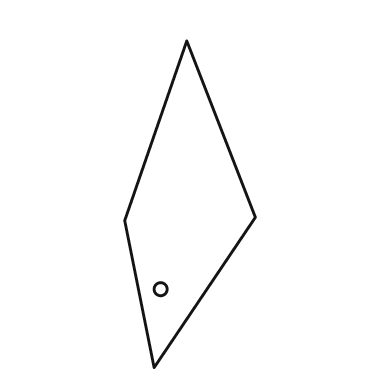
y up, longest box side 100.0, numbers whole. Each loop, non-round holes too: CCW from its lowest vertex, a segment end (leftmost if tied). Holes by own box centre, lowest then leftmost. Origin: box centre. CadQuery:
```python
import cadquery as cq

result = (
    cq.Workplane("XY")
    .moveTo(-11.0, -50.0)
    .lineTo(20.0, -4.0)
    .lineTo(-1.0, 50.0)
    .lineTo(-20.0, -5.0)
    .close()
    .moveTo(-9.0, -26.0)
    .circle(2.0)
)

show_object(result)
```